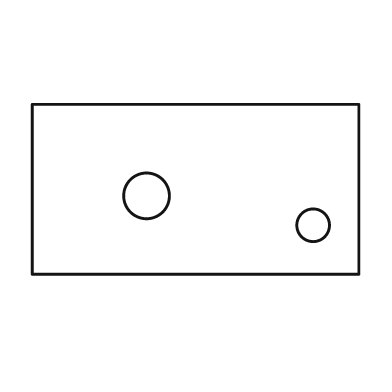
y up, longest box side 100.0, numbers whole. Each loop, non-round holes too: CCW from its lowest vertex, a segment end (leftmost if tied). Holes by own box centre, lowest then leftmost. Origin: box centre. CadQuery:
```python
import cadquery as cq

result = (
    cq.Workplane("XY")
    .moveTo(-50.0, -26.0)
    .lineTo(50.0, -26.0)
    .lineTo(50.0, 26.0)
    .lineTo(-50.0, 26.0)
    .close()
    .moveTo(36.0, -11.0)
    .circle(5.0)
    .moveTo(-15.0, -2.0)
    .circle(7.0)
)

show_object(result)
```